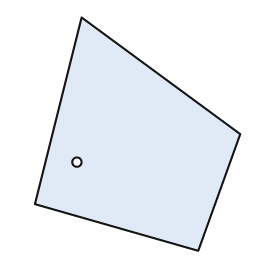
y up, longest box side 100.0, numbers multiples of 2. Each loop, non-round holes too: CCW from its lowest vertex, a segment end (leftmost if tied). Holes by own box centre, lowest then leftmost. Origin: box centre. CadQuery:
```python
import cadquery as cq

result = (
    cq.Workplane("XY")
    .moveTo(26.0, -50.0)
    .lineTo(44.0, 0.0)
    .lineTo(-24.0, 50.0)
    .lineTo(-44.0, -30.0)
    .close()
    .moveTo(-26.0, -12.0)
    .circle(2.0)
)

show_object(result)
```